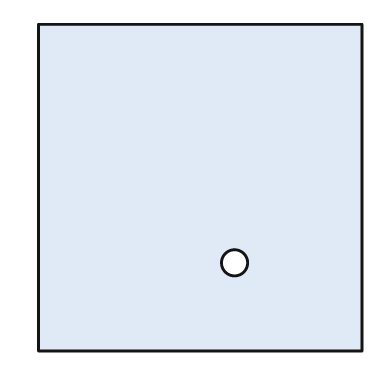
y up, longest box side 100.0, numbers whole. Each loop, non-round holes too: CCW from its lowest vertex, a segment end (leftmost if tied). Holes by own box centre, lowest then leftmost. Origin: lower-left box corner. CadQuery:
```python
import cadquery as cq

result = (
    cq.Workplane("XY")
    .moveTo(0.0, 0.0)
    .lineTo(99.0, 0.0)
    .lineTo(99.0, 100.0)
    .lineTo(0.0, 100.0)
    .close()
    .moveTo(60.0, 27.0)
    .circle(4.0)
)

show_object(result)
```